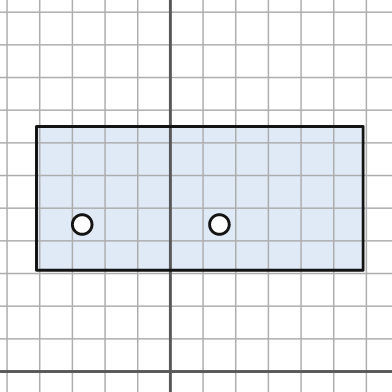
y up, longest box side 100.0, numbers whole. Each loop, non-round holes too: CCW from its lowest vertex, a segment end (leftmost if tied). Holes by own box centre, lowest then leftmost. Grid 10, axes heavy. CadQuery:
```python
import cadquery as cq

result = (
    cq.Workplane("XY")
    .moveTo(-41.0, 31.0)
    .lineTo(59.0, 31.0)
    .lineTo(59.0, 75.0)
    .lineTo(-41.0, 75.0)
    .close()
    .moveTo(-27.0, 45.0)
    .circle(3.0)
    .moveTo(15.0, 45.0)
    .circle(3.0)
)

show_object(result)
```